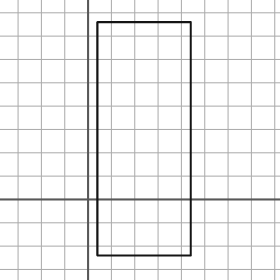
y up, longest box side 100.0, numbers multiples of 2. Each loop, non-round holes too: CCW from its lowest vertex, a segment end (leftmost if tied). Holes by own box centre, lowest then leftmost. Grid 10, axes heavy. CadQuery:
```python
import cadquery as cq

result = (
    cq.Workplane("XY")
    .moveTo(4.0, -24.0)
    .lineTo(44.0, -24.0)
    .lineTo(44.0, 76.0)
    .lineTo(4.0, 76.0)
    .close()
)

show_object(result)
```